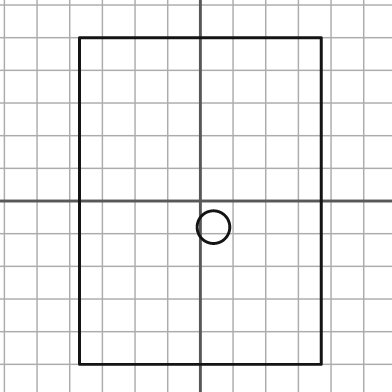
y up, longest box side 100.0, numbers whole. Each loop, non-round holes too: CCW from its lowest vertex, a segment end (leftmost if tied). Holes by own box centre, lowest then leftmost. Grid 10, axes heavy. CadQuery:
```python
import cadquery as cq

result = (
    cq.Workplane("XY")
    .moveTo(-37.0, -50.0)
    .lineTo(37.0, -50.0)
    .lineTo(37.0, 50.0)
    .lineTo(-37.0, 50.0)
    .close()
    .moveTo(4.0, -8.0)
    .circle(5.0)
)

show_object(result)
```